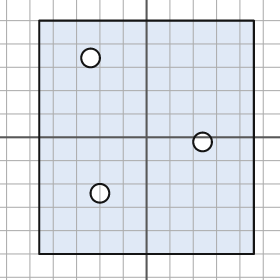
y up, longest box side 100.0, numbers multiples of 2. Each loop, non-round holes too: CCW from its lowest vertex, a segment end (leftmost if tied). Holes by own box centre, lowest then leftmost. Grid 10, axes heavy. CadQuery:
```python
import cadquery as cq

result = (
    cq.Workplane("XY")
    .moveTo(-46.0, -50.0)
    .lineTo(46.0, -50.0)
    .lineTo(46.0, 50.0)
    .lineTo(-46.0, 50.0)
    .close()
    .moveTo(-20.0, -24.0)
    .circle(4.0)
    .moveTo(24.0, -2.0)
    .circle(4.0)
    .moveTo(-24.0, 34.0)
    .circle(4.0)
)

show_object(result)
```